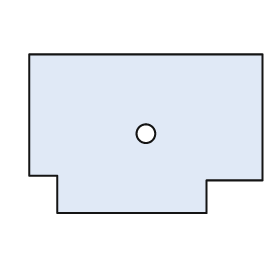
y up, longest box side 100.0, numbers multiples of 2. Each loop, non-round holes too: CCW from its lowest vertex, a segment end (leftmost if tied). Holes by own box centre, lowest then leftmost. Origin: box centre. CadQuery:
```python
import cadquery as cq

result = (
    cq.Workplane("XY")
    .moveTo(-38.0, -34.0)
    .lineTo(26.0, -34.0)
    .lineTo(26.0, -20.0)
    .lineTo(50.0, -20.0)
    .lineTo(50.0, 34.0)
    .lineTo(-50.0, 34.0)
    .lineTo(-50.0, -18.0)
    .lineTo(-38.0, -18.0)
    .close()
    .moveTo(0.0, 0.0)
    .circle(4.0)
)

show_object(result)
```